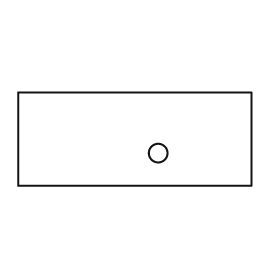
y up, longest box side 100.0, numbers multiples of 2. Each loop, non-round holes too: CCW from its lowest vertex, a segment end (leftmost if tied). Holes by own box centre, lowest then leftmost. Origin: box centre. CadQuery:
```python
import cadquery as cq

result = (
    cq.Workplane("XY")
    .moveTo(-50.0, -20.0)
    .lineTo(50.0, -20.0)
    .lineTo(50.0, 20.0)
    .lineTo(-50.0, 20.0)
    .close()
    .moveTo(10.0, -6.0)
    .circle(4.0)
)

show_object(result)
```